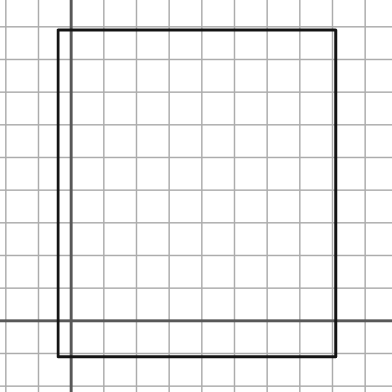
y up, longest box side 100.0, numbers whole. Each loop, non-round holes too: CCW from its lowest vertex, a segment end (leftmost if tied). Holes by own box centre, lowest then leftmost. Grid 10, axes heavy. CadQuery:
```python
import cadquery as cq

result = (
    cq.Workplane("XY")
    .moveTo(-4.0, -11.0)
    .lineTo(81.0, -11.0)
    .lineTo(81.0, 89.0)
    .lineTo(-4.0, 89.0)
    .close()
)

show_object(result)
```